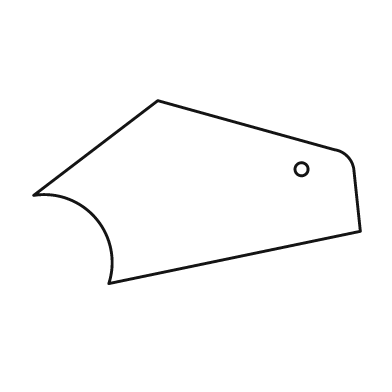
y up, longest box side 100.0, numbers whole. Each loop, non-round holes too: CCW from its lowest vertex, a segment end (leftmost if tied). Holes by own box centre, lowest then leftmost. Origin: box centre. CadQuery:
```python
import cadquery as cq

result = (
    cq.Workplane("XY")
    .moveTo(-27.0, -28.0)
    .lineTo(50.0, -12.0)
    .lineTo(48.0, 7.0)
    .threePointArc((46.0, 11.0), (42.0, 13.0))
    .lineTo(-12.0, 28.0)
    .lineTo(-50.0, -1.0)
    .threePointArc((-31.0, -8.0), (-27.0, -28.0))
    .close()
    .moveTo(32.0, 7.0)
    .circle(2.0)
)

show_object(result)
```